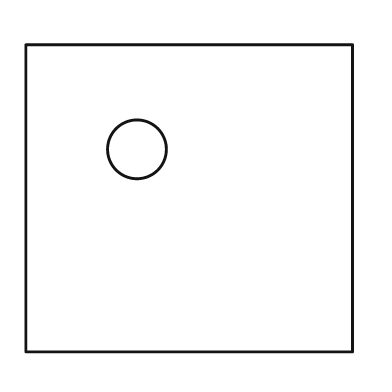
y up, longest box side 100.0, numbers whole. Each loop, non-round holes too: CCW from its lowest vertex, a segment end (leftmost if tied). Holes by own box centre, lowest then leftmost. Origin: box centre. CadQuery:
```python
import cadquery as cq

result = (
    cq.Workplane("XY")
    .moveTo(-50.0, -47.0)
    .lineTo(50.0, -47.0)
    .lineTo(50.0, 47.0)
    .lineTo(-50.0, 47.0)
    .close()
    .moveTo(-16.0, 15.0)
    .circle(9.0)
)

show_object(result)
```